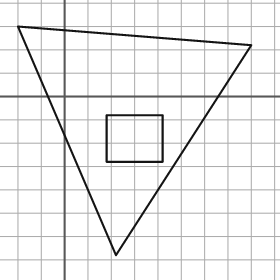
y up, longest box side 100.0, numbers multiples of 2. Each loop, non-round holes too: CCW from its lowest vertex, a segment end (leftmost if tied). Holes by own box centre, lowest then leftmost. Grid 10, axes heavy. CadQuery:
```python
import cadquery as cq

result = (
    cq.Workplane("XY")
    .moveTo(22.0, -68.0)
    .lineTo(80.0, 22.0)
    .lineTo(-20.0, 30.0)
    .close()
    .moveTo(18.0, -28.0)
    .lineTo(42.0, -28.0)
    .lineTo(42.0, -8.0)
    .lineTo(18.0, -8.0)
    .close()
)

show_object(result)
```